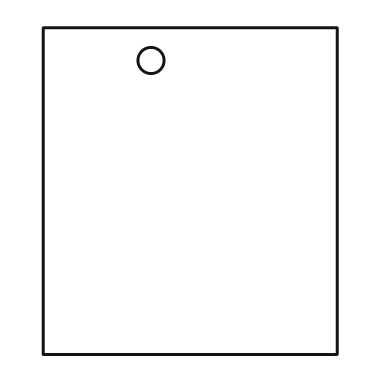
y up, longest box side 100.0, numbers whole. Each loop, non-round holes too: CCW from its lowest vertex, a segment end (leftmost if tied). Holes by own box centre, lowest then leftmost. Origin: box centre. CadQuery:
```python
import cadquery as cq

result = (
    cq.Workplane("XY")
    .moveTo(-45.0, -50.0)
    .lineTo(45.0, -50.0)
    .lineTo(45.0, 50.0)
    .lineTo(-45.0, 50.0)
    .close()
    .moveTo(-12.0, 40.0)
    .circle(4.0)
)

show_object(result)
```